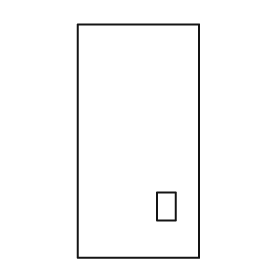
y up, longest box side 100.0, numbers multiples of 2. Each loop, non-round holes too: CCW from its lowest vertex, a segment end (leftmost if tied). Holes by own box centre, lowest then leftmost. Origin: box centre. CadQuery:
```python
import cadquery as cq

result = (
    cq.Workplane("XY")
    .moveTo(-26.0, -50.0)
    .lineTo(26.0, -50.0)
    .lineTo(26.0, 50.0)
    .lineTo(-26.0, 50.0)
    .close()
    .moveTo(8.0, -34.0)
    .lineTo(16.0, -34.0)
    .lineTo(16.0, -22.0)
    .lineTo(8.0, -22.0)
    .close()
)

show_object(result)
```